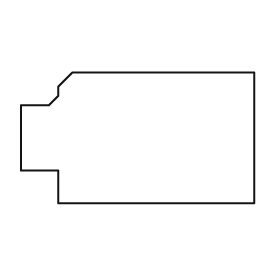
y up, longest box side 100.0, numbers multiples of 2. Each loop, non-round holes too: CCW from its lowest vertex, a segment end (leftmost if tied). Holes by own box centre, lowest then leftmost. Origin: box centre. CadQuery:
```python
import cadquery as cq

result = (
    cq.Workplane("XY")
    .moveTo(-34.0, -28.0)
    .lineTo(50.0, -28.0)
    .lineTo(50.0, 28.0)
    .lineTo(-28.0, 28.0)
    .lineTo(-34.0, 22.0)
    .lineTo(-34.0, 18.0)
    .lineTo(-38.0, 14.0)
    .lineTo(-50.0, 14.0)
    .lineTo(-50.0, -14.0)
    .lineTo(-34.0, -14.0)
    .close()
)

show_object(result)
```